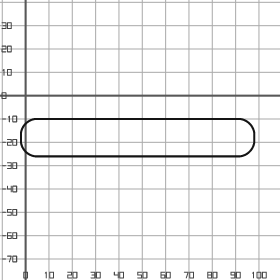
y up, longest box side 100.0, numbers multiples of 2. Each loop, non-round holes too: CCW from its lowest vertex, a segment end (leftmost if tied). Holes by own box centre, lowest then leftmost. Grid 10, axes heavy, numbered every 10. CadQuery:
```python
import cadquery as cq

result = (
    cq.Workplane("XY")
    .moveTo(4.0, -26.0)
    .lineTo(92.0, -26.0)
    .threePointArc((96.0, -24.0), (98.0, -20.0))
    .lineTo(98.0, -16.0)
    .threePointArc((96.0, -12.0), (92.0, -10.0))
    .lineTo(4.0, -10.0)
    .threePointArc((0.0, -12.0), (-2.0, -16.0))
    .lineTo(-2.0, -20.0)
    .threePointArc((0.0, -24.0), (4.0, -26.0))
    .close()
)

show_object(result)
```